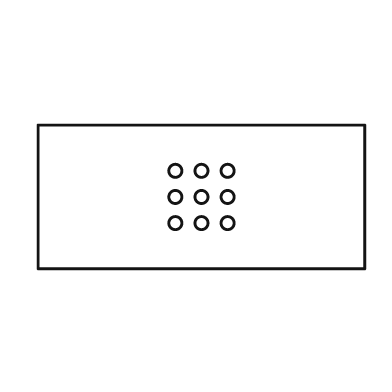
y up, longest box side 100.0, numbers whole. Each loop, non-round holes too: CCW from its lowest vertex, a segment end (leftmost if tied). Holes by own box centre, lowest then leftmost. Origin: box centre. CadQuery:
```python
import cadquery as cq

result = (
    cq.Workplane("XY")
    .moveTo(-50.0, -22.0)
    .lineTo(50.0, -22.0)
    .lineTo(50.0, 22.0)
    .lineTo(-50.0, 22.0)
    .close()
    .moveTo(-8.0, -8.0)
    .circle(2.0)
    .moveTo(0.0, -8.0)
    .circle(2.0)
    .moveTo(8.0, -8.0)
    .circle(2.0)
    .moveTo(-8.0, 0.0)
    .circle(2.0)
    .moveTo(0.0, 0.0)
    .circle(2.0)
    .moveTo(8.0, 0.0)
    .circle(2.0)
    .moveTo(-8.0, 8.0)
    .circle(2.0)
    .moveTo(0.0, 8.0)
    .circle(2.0)
    .moveTo(8.0, 8.0)
    .circle(2.0)
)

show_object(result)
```